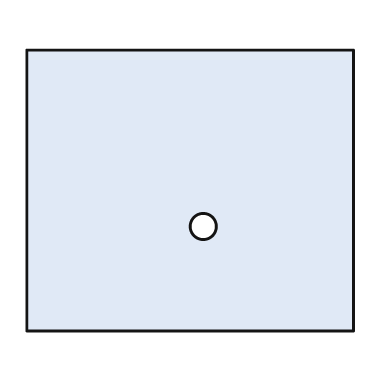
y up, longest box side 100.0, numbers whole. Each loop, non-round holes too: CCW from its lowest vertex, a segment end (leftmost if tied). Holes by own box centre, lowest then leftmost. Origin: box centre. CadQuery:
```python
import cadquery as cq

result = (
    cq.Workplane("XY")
    .moveTo(-50.0, -43.0)
    .lineTo(50.0, -43.0)
    .lineTo(50.0, 43.0)
    .lineTo(-50.0, 43.0)
    .close()
    .moveTo(4.0, -11.0)
    .circle(4.0)
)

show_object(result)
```